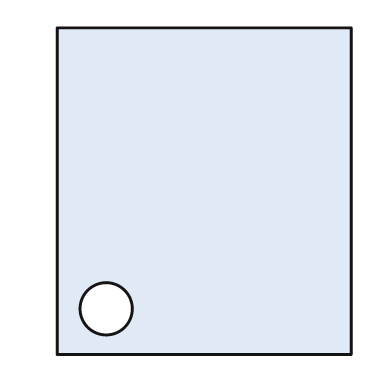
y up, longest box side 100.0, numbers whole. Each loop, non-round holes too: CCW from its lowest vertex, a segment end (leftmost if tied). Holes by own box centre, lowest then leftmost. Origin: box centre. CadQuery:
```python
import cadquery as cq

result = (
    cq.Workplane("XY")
    .moveTo(-45.0, -50.0)
    .lineTo(45.0, -50.0)
    .lineTo(45.0, 50.0)
    .lineTo(-45.0, 50.0)
    .close()
    .moveTo(-30.0, -36.0)
    .circle(8.0)
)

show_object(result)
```